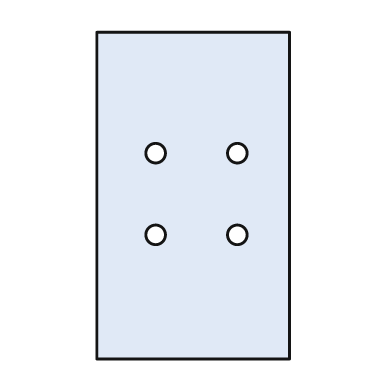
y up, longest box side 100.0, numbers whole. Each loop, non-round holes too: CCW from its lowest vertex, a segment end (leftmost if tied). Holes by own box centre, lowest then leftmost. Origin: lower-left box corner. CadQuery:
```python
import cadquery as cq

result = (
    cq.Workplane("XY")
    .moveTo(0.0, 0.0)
    .lineTo(59.0, 0.0)
    .lineTo(59.0, 100.0)
    .lineTo(0.0, 100.0)
    .close()
    .moveTo(18.0, 38.0)
    .circle(3.0)
    .moveTo(43.0, 38.0)
    .circle(3.0)
    .moveTo(18.0, 63.0)
    .circle(3.0)
    .moveTo(43.0, 63.0)
    .circle(3.0)
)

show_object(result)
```